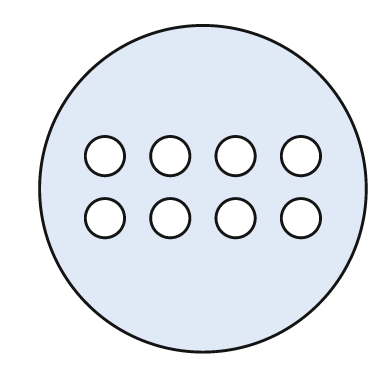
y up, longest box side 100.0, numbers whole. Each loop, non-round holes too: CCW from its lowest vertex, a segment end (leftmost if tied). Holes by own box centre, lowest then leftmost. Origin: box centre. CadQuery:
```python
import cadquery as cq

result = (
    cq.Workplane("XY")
    .moveTo(0.0, 0.0)
    .circle(50.0)
    .moveTo(-30.0, -9.0)
    .circle(6.0)
    .moveTo(-10.0, -9.0)
    .circle(6.0)
    .moveTo(10.0, -9.0)
    .circle(6.0)
    .moveTo(30.0, -9.0)
    .circle(6.0)
    .moveTo(-30.0, 10.0)
    .circle(6.0)
    .moveTo(-10.0, 10.0)
    .circle(6.0)
    .moveTo(10.0, 10.0)
    .circle(6.0)
    .moveTo(30.0, 10.0)
    .circle(6.0)
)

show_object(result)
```